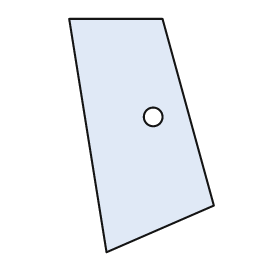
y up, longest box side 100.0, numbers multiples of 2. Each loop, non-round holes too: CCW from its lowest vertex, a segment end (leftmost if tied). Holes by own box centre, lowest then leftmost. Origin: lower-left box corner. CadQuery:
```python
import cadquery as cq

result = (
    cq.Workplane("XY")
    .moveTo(16.0, 0.0)
    .lineTo(62.0, 20.0)
    .lineTo(40.0, 100.0)
    .lineTo(0.0, 100.0)
    .close()
    .moveTo(36.0, 58.0)
    .circle(4.0)
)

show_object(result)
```